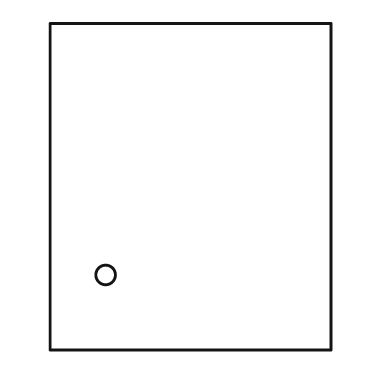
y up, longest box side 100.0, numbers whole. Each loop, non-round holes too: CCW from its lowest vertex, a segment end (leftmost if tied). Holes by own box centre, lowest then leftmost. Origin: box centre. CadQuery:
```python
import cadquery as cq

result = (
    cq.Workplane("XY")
    .moveTo(-43.0, -50.0)
    .lineTo(43.0, -50.0)
    .lineTo(43.0, 50.0)
    .lineTo(-43.0, 50.0)
    .close()
    .moveTo(-26.0, -27.0)
    .circle(3.0)
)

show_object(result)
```